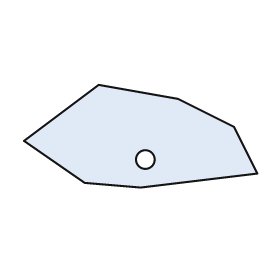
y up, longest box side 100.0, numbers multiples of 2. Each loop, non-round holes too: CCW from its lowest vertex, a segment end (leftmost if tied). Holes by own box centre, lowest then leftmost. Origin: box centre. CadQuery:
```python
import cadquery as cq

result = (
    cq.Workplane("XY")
    .moveTo(0.0, -22.0)
    .lineTo(50.0, -16.0)
    .lineTo(40.0, 4.0)
    .lineTo(16.0, 16.0)
    .lineTo(-18.0, 22.0)
    .lineTo(-50.0, -2.0)
    .lineTo(-24.0, -20.0)
    .close()
    .moveTo(2.0, -10.0)
    .circle(4.0)
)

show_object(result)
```